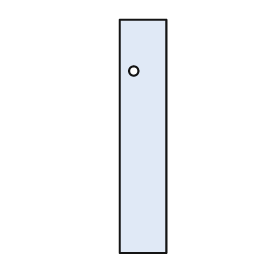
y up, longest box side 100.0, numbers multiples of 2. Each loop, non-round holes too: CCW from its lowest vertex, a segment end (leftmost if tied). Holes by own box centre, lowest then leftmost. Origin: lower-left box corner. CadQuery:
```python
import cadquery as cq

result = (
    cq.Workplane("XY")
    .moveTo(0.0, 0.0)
    .lineTo(20.0, 0.0)
    .lineTo(20.0, 100.0)
    .lineTo(0.0, 100.0)
    .close()
    .moveTo(6.0, 78.0)
    .circle(2.0)
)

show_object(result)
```